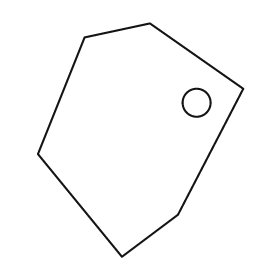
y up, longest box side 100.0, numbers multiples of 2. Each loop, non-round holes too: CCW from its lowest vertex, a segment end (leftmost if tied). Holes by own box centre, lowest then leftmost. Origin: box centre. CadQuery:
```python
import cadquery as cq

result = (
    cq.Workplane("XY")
    .moveTo(-8.0, -50.0)
    .lineTo(16.0, -32.0)
    .lineTo(44.0, 22.0)
    .lineTo(4.0, 50.0)
    .lineTo(-24.0, 44.0)
    .lineTo(-44.0, -6.0)
    .close()
    .moveTo(24.0, 16.0)
    .circle(6.0)
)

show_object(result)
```